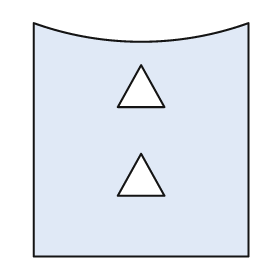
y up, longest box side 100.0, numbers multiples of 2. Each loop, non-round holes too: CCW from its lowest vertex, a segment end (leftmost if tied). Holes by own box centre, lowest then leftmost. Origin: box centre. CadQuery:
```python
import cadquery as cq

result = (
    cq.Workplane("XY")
    .moveTo(-46.0, -50.0)
    .lineTo(46.0, -50.0)
    .lineTo(46.0, 50.0)
    .threePointArc((0.0, 42.0), (-46.0, 50.0))
    .close()
    .moveTo(-10.0, -24.0)
    .lineTo(10.0, -24.0)
    .lineTo(0.0, -6.0)
    .close()
    .moveTo(-10.0, 14.0)
    .lineTo(10.0, 14.0)
    .lineTo(0.0, 32.0)
    .close()
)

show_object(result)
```